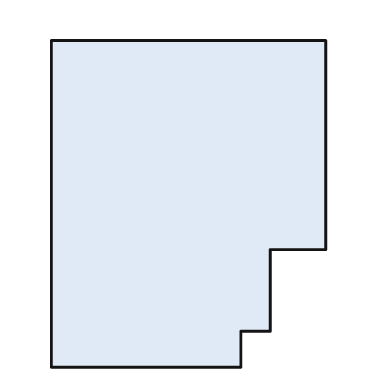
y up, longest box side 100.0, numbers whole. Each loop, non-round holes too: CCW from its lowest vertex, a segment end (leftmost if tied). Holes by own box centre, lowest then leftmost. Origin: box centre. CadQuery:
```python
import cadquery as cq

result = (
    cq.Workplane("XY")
    .moveTo(-42.0, -50.0)
    .lineTo(16.0, -50.0)
    .lineTo(16.0, -39.0)
    .lineTo(25.0, -39.0)
    .lineTo(25.0, -14.0)
    .lineTo(42.0, -14.0)
    .lineTo(42.0, 50.0)
    .lineTo(-42.0, 50.0)
    .close()
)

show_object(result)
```